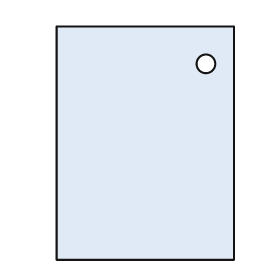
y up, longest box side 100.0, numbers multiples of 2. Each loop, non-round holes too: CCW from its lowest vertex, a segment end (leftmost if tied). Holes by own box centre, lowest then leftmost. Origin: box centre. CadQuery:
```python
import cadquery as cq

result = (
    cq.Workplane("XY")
    .moveTo(-38.0, -50.0)
    .lineTo(38.0, -50.0)
    .lineTo(38.0, 50.0)
    .lineTo(-38.0, 50.0)
    .close()
    .moveTo(26.0, 34.0)
    .circle(4.0)
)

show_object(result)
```